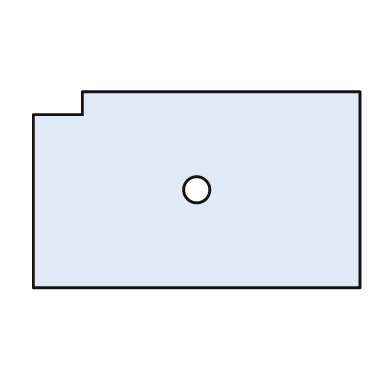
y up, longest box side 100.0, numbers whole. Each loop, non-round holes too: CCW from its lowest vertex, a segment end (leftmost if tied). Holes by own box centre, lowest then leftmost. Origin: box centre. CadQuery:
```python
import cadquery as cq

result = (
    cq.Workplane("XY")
    .moveTo(-50.0, -30.0)
    .lineTo(50.0, -30.0)
    .lineTo(50.0, 30.0)
    .lineTo(-35.0, 30.0)
    .lineTo(-35.0, 23.0)
    .lineTo(-50.0, 23.0)
    .close()
    .moveTo(0.0, 0.0)
    .circle(4.0)
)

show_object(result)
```